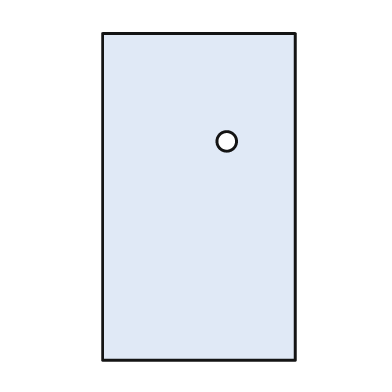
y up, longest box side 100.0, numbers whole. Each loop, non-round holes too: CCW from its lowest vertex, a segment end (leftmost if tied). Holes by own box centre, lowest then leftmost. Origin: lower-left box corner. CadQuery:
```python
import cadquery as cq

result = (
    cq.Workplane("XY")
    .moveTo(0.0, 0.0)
    .lineTo(59.0, 0.0)
    .lineTo(59.0, 100.0)
    .lineTo(0.0, 100.0)
    .close()
    .moveTo(38.0, 67.0)
    .circle(3.0)
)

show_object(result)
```